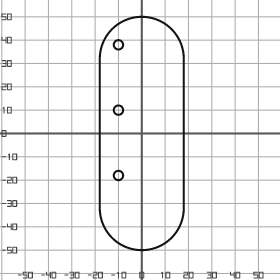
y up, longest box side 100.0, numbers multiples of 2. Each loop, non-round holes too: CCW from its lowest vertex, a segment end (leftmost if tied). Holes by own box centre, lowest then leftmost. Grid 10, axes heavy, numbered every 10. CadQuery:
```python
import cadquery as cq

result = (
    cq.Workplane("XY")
    .moveTo(-18.0, -32.0)
    .threePointArc((0.0, -50.0), (18.0, -32.0))
    .lineTo(18.0, 32.0)
    .threePointArc((0.0, 50.0), (-18.0, 32.0))
    .close()
    .moveTo(-10.0, -18.0)
    .circle(2.0)
    .moveTo(-10.0, 10.0)
    .circle(2.0)
    .moveTo(-10.0, 38.0)
    .circle(2.0)
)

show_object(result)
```